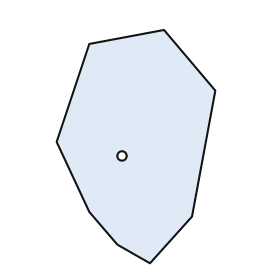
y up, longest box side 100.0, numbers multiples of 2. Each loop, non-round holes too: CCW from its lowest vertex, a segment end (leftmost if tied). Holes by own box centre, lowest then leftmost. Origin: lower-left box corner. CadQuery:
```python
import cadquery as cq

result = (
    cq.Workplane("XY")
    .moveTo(40.0, 0.0)
    .lineTo(58.0, 20.0)
    .lineTo(68.0, 74.0)
    .lineTo(46.0, 100.0)
    .lineTo(14.0, 94.0)
    .lineTo(0.0, 52.0)
    .lineTo(14.0, 22.0)
    .lineTo(26.0, 8.0)
    .close()
    .moveTo(28.0, 46.0)
    .circle(2.0)
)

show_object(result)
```